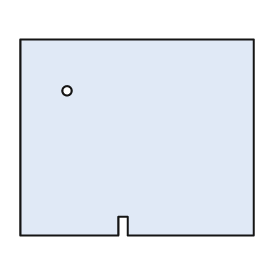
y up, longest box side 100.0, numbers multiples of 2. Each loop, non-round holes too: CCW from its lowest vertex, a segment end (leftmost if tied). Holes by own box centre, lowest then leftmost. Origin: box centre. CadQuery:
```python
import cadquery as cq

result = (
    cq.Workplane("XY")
    .moveTo(-50.0, -42.0)
    .lineTo(-8.0, -42.0)
    .lineTo(-8.0, -34.0)
    .lineTo(-4.0, -34.0)
    .lineTo(-4.0, -42.0)
    .lineTo(50.0, -42.0)
    .lineTo(50.0, 42.0)
    .lineTo(-50.0, 42.0)
    .close()
    .moveTo(-30.0, 20.0)
    .circle(2.0)
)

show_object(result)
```